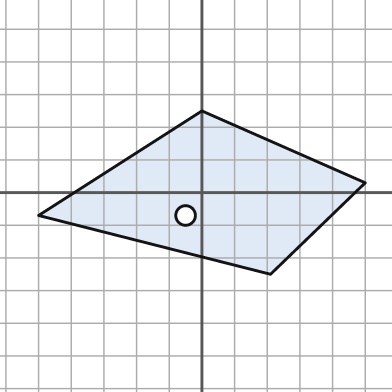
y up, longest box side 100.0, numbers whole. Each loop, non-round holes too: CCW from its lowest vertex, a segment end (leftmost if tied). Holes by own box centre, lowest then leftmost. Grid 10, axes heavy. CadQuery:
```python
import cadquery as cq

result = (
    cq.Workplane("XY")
    .moveTo(21.0, -25.0)
    .lineTo(50.0, 3.0)
    .lineTo(0.0, 25.0)
    .lineTo(-50.0, -7.0)
    .close()
    .moveTo(-5.0, -7.0)
    .circle(3.0)
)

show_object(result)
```